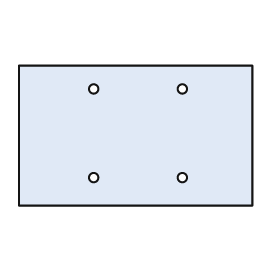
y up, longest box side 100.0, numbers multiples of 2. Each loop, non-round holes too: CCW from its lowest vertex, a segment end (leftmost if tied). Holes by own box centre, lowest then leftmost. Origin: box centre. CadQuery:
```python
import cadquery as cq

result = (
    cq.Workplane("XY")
    .moveTo(-50.0, -30.0)
    .lineTo(50.0, -30.0)
    .lineTo(50.0, 30.0)
    .lineTo(-50.0, 30.0)
    .close()
    .moveTo(-18.0, -18.0)
    .circle(2.0)
    .moveTo(20.0, -18.0)
    .circle(2.0)
    .moveTo(-18.0, 20.0)
    .circle(2.0)
    .moveTo(20.0, 20.0)
    .circle(2.0)
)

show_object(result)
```